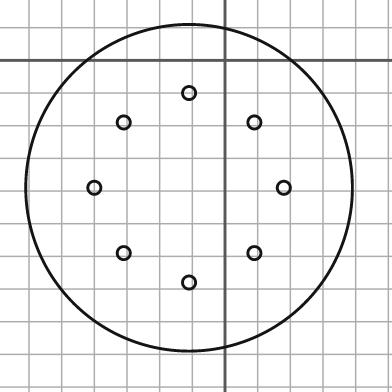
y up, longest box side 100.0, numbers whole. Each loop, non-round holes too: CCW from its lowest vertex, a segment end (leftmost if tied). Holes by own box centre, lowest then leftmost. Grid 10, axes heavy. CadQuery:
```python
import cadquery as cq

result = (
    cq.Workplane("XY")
    .moveTo(-11.0, -39.0)
    .circle(50.0)
    .moveTo(-11.0, -68.0)
    .circle(2.0)
    .moveTo(-31.0, -59.0)
    .circle(2.0)
    .moveTo(9.0, -59.0)
    .circle(2.0)
    .moveTo(-40.0, -39.0)
    .circle(2.0)
    .moveTo(18.0, -39.0)
    .circle(2.0)
    .moveTo(-31.0, -19.0)
    .circle(2.0)
    .moveTo(9.0, -19.0)
    .circle(2.0)
    .moveTo(-11.0, -10.0)
    .circle(2.0)
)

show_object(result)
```